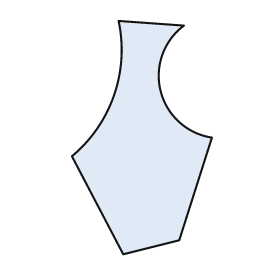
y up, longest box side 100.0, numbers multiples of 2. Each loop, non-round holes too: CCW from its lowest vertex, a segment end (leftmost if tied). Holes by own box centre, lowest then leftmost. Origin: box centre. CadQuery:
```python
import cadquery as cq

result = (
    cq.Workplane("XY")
    .moveTo(-8.0, -50.0)
    .lineTo(16.0, -44.0)
    .lineTo(30.0, 0.0)
    .threePointArc((8.0, 20.0), (18.0, 48.0))
    .lineTo(-10.0, 50.0)
    .threePointArc((-12.0, 18.0), (-30.0, -8.0))
    .close()
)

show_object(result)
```